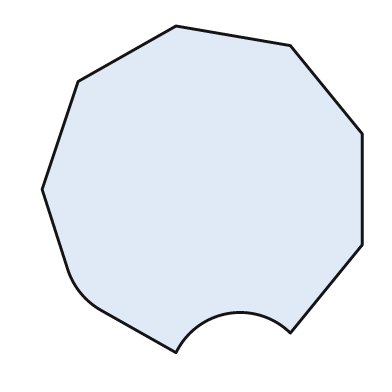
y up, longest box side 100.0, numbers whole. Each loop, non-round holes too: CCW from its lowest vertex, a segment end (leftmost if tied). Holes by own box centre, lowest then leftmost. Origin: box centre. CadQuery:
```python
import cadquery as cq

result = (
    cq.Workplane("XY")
    .moveTo(-8.0, -50.0)
    .threePointArc((8.0, -38.0), (27.0, -44.0))
    .lineTo(49.0, -17.0)
    .lineTo(49.0, 17.0)
    .lineTo(27.0, 44.0)
    .lineTo(-8.0, 50.0)
    .lineTo(-38.0, 33.0)
    .lineTo(-49.0, 0.0)
    .lineTo(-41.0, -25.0)
    .threePointArc((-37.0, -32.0), (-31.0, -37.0))
    .close()
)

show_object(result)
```